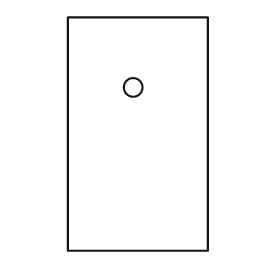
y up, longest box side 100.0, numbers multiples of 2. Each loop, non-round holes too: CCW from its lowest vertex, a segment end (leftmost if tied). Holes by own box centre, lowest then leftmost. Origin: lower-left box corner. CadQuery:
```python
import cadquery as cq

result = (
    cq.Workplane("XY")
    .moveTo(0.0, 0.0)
    .lineTo(60.0, 0.0)
    .lineTo(60.0, 100.0)
    .lineTo(0.0, 100.0)
    .close()
    .moveTo(28.0, 70.0)
    .circle(4.0)
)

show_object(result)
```